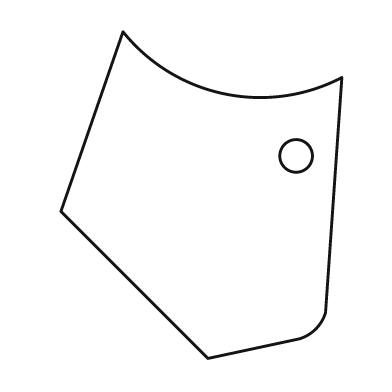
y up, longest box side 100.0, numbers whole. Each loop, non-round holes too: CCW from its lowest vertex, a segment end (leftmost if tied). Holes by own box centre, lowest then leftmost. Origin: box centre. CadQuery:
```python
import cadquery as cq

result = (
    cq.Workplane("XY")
    .moveTo(2.0, -50.0)
    .lineTo(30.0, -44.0)
    .threePointArc((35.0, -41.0), (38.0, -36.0))
    .lineTo(43.0, 36.0)
    .threePointArc((7.0, 31.0), (-24.0, 50.0))
    .lineTo(-43.0, -5.0)
    .close()
    .moveTo(29.0, 12.0)
    .circle(5.0)
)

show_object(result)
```